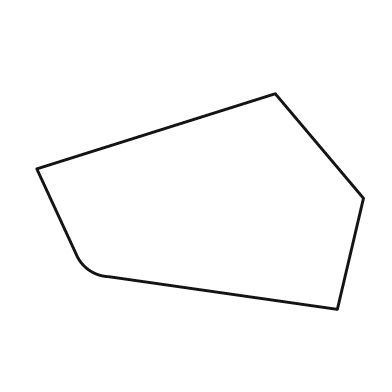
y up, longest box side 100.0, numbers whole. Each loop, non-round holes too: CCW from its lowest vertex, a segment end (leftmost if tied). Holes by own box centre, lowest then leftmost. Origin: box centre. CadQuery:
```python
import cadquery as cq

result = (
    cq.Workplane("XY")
    .moveTo(42.0, -33.0)
    .lineTo(50.0, 1.0)
    .lineTo(23.0, 33.0)
    .lineTo(-50.0, 10.0)
    .lineTo(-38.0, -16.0)
    .threePointArc((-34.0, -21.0), (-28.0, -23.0))
    .close()
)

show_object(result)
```